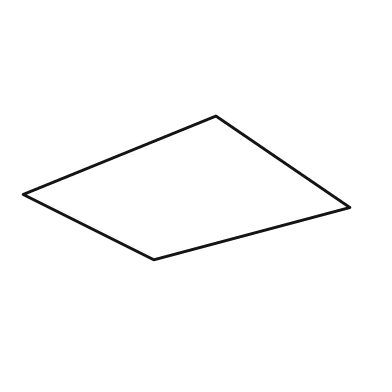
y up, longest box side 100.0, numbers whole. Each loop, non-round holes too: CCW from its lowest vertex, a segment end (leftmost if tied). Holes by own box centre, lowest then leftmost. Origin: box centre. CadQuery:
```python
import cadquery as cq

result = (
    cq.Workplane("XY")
    .moveTo(-10.0, -22.0)
    .lineTo(50.0, -6.0)
    .lineTo(9.0, 22.0)
    .lineTo(-50.0, -2.0)
    .close()
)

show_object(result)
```